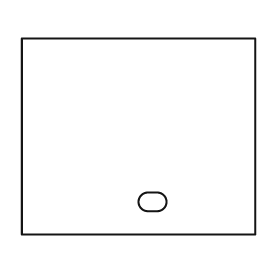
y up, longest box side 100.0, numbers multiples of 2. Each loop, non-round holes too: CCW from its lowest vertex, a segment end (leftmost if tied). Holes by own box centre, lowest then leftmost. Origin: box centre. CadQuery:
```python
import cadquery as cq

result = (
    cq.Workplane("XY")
    .moveTo(-50.0, -42.0)
    .lineTo(50.0, -42.0)
    .lineTo(50.0, 42.0)
    .lineTo(-50.0, 42.0)
    .close()
    .moveTo(4.0, -32.0)
    .lineTo(8.0, -32.0)
    .threePointArc((12.0, -28.0), (8.0, -24.0))
    .lineTo(4.0, -24.0)
    .threePointArc((0.0, -28.0), (4.0, -32.0))
    .close()
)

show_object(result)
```